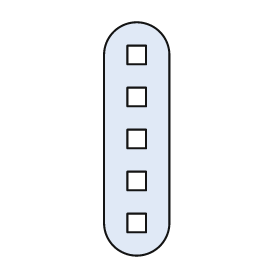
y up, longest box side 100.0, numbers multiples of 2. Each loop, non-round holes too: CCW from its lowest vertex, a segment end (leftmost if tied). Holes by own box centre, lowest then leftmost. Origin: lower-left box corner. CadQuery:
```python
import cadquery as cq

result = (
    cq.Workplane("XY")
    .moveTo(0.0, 14.0)
    .threePointArc((14.0, 0.0), (28.0, 14.0))
    .lineTo(28.0, 86.0)
    .threePointArc((14.0, 100.0), (0.0, 86.0))
    .close()
    .moveTo(10.0, 10.0)
    .lineTo(18.0, 10.0)
    .lineTo(18.0, 18.0)
    .lineTo(10.0, 18.0)
    .close()
    .moveTo(10.0, 28.0)
    .lineTo(18.0, 28.0)
    .lineTo(18.0, 36.0)
    .lineTo(10.0, 36.0)
    .close()
    .moveTo(10.0, 46.0)
    .lineTo(18.0, 46.0)
    .lineTo(18.0, 54.0)
    .lineTo(10.0, 54.0)
    .close()
    .moveTo(10.0, 64.0)
    .lineTo(18.0, 64.0)
    .lineTo(18.0, 72.0)
    .lineTo(10.0, 72.0)
    .close()
    .moveTo(10.0, 82.0)
    .lineTo(18.0, 82.0)
    .lineTo(18.0, 90.0)
    .lineTo(10.0, 90.0)
    .close()
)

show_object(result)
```